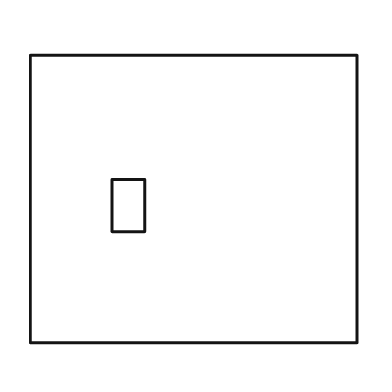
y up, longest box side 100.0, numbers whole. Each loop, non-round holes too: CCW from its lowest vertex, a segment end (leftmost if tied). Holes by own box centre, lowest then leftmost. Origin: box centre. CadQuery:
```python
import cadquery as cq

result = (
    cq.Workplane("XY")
    .moveTo(-50.0, -44.0)
    .lineTo(50.0, -44.0)
    .lineTo(50.0, 44.0)
    .lineTo(-50.0, 44.0)
    .close()
    .moveTo(-25.0, -10.0)
    .lineTo(-15.0, -10.0)
    .lineTo(-15.0, 6.0)
    .lineTo(-25.0, 6.0)
    .close()
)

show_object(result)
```